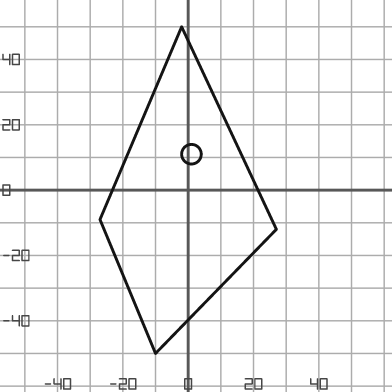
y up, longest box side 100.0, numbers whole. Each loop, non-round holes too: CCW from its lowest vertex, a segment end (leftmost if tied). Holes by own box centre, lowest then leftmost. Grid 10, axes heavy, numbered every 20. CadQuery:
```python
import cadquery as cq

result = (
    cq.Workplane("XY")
    .moveTo(-10.0, -50.0)
    .lineTo(27.0, -12.0)
    .lineTo(-2.0, 50.0)
    .lineTo(-27.0, -9.0)
    .close()
    .moveTo(1.0, 11.0)
    .circle(3.0)
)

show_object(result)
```